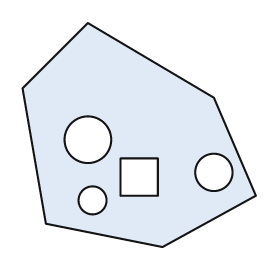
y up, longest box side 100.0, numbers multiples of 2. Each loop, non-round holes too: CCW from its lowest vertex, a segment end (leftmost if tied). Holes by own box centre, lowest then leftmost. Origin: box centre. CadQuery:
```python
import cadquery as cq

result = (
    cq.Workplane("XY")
    .moveTo(10.0, -48.0)
    .lineTo(50.0, -26.0)
    .lineTo(32.0, 16.0)
    .lineTo(-22.0, 48.0)
    .lineTo(-50.0, 20.0)
    .lineTo(-40.0, -38.0)
    .close()
    .moveTo(-20.0, -28.0)
    .circle(6.0)
    .moveTo(-8.0, -26.0)
    .lineTo(8.0, -26.0)
    .lineTo(8.0, -10.0)
    .lineTo(-8.0, -10.0)
    .close()
    .moveTo(32.0, -16.0)
    .circle(8.0)
    .moveTo(-22.0, -2.0)
    .circle(10.0)
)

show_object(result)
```